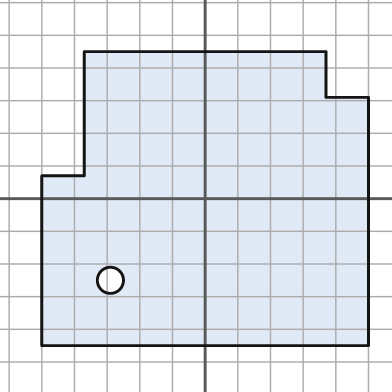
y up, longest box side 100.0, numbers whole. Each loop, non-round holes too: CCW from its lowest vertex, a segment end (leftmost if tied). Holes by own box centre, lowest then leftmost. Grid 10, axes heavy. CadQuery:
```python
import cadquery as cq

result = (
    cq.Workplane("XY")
    .moveTo(-50.0, -45.0)
    .lineTo(50.0, -45.0)
    .lineTo(50.0, 31.0)
    .lineTo(37.0, 31.0)
    .lineTo(37.0, 45.0)
    .lineTo(-37.0, 45.0)
    .lineTo(-37.0, 7.0)
    .lineTo(-50.0, 7.0)
    .close()
    .moveTo(-29.0, -25.0)
    .circle(4.0)
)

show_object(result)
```